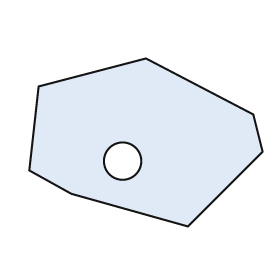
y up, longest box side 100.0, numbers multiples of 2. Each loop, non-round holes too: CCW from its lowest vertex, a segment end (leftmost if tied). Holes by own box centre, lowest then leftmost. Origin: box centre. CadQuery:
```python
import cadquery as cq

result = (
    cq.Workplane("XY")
    .moveTo(18.0, -36.0)
    .lineTo(50.0, -4.0)
    .lineTo(46.0, 12.0)
    .lineTo(0.0, 36.0)
    .lineTo(-46.0, 24.0)
    .lineTo(-50.0, -12.0)
    .lineTo(-32.0, -22.0)
    .close()
    .moveTo(-10.0, -8.0)
    .circle(8.0)
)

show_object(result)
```